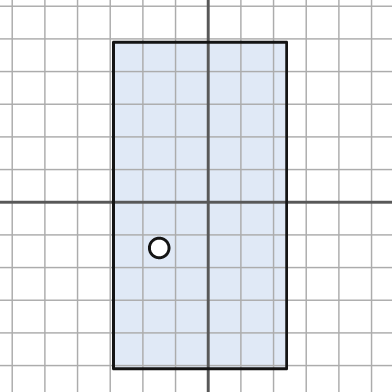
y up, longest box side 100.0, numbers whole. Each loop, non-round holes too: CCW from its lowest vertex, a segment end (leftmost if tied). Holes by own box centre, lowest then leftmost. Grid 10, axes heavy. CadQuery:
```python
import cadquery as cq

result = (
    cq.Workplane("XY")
    .moveTo(-29.0, -51.0)
    .lineTo(24.0, -51.0)
    .lineTo(24.0, 49.0)
    .lineTo(-29.0, 49.0)
    .close()
    .moveTo(-15.0, -14.0)
    .circle(3.0)
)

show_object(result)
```